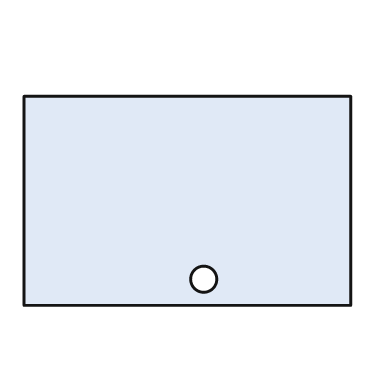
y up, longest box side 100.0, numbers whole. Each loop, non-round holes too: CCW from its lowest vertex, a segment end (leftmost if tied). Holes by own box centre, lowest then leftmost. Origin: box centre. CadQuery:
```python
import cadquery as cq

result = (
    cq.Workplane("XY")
    .moveTo(-50.0, -32.0)
    .lineTo(50.0, -32.0)
    .lineTo(50.0, 32.0)
    .lineTo(-50.0, 32.0)
    .close()
    .moveTo(5.0, -24.0)
    .circle(4.0)
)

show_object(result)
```